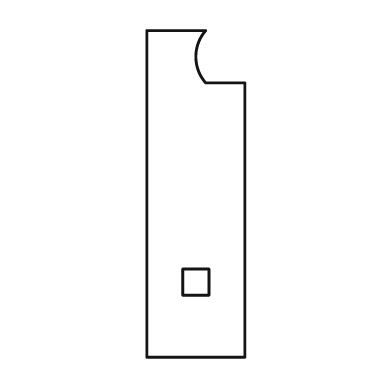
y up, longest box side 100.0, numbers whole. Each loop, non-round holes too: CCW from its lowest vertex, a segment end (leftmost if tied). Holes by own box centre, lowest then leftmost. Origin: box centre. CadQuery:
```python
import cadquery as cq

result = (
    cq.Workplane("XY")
    .moveTo(-15.0, -50.0)
    .lineTo(15.0, -50.0)
    .lineTo(15.0, 34.0)
    .lineTo(3.0, 34.0)
    .threePointArc((0.0, 42.0), (3.0, 50.0))
    .lineTo(-15.0, 50.0)
    .close()
    .moveTo(-4.0, -31.0)
    .lineTo(4.0, -31.0)
    .lineTo(4.0, -23.0)
    .lineTo(-4.0, -23.0)
    .close()
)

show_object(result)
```